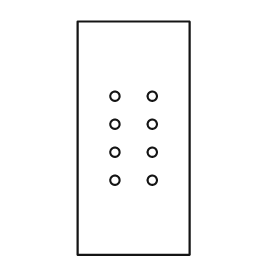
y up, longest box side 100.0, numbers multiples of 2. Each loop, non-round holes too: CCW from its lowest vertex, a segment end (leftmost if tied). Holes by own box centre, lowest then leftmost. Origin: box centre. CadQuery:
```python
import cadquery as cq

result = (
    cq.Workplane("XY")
    .moveTo(-24.0, -50.0)
    .lineTo(24.0, -50.0)
    .lineTo(24.0, 50.0)
    .lineTo(-24.0, 50.0)
    .close()
    .moveTo(-8.0, -18.0)
    .circle(2.0)
    .moveTo(8.0, -18.0)
    .circle(2.0)
    .moveTo(-8.0, -6.0)
    .circle(2.0)
    .moveTo(8.0, -6.0)
    .circle(2.0)
    .moveTo(-8.0, 6.0)
    .circle(2.0)
    .moveTo(8.0, 6.0)
    .circle(2.0)
    .moveTo(-8.0, 18.0)
    .circle(2.0)
    .moveTo(8.0, 18.0)
    .circle(2.0)
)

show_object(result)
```